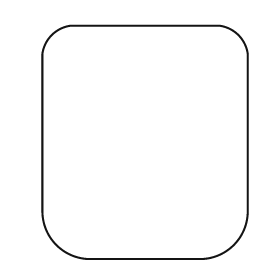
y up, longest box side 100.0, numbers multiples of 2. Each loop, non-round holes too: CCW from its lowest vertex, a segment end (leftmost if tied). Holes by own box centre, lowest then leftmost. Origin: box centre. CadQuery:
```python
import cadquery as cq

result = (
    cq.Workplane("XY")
    .moveTo(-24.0, -50.0)
    .lineTo(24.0, -50.0)
    .threePointArc((38.0, -44.0), (44.0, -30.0))
    .lineTo(44.0, 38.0)
    .threePointArc((40.0, 46.0), (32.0, 50.0))
    .lineTo(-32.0, 50.0)
    .threePointArc((-40.0, 46.0), (-44.0, 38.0))
    .lineTo(-44.0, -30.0)
    .threePointArc((-38.0, -44.0), (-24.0, -50.0))
    .close()
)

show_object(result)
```